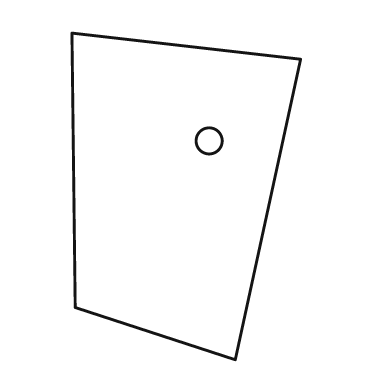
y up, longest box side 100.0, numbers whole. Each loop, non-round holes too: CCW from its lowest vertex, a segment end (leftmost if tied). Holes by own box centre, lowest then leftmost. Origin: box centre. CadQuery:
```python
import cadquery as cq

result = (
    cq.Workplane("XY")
    .moveTo(15.0, -50.0)
    .lineTo(35.0, 42.0)
    .lineTo(-35.0, 50.0)
    .lineTo(-34.0, -34.0)
    .close()
    .moveTo(7.0, 17.0)
    .circle(4.0)
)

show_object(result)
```